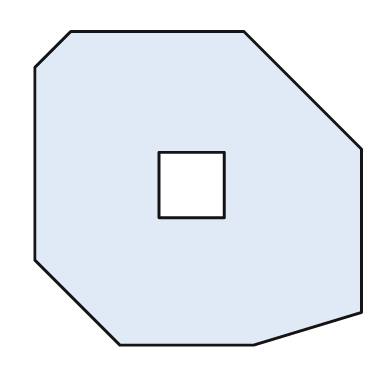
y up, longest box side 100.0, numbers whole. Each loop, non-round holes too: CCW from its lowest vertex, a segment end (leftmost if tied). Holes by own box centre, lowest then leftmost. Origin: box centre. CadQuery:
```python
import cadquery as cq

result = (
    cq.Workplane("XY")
    .moveTo(-24.0, -48.0)
    .lineTo(17.0, -48.0)
    .lineTo(50.0, -38.0)
    .lineTo(50.0, 12.0)
    .lineTo(14.0, 48.0)
    .lineTo(-39.0, 48.0)
    .lineTo(-50.0, 37.0)
    .lineTo(-50.0, -22.0)
    .close()
    .moveTo(-12.0, -9.0)
    .lineTo(8.0, -9.0)
    .lineTo(8.0, 11.0)
    .lineTo(-12.0, 11.0)
    .close()
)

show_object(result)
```